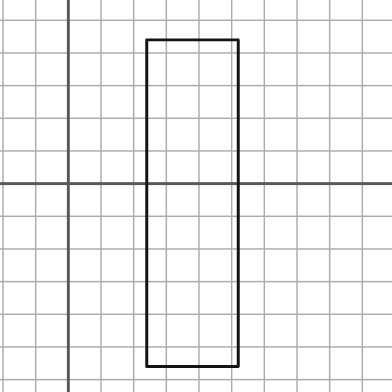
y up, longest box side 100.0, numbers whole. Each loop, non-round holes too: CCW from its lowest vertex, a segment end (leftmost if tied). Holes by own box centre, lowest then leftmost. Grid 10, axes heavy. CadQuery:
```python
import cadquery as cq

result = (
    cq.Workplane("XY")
    .moveTo(24.0, -56.0)
    .lineTo(52.0, -56.0)
    .lineTo(52.0, 44.0)
    .lineTo(24.0, 44.0)
    .close()
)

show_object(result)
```